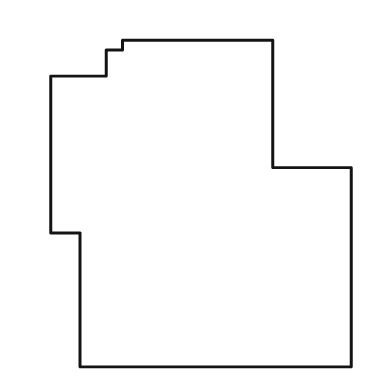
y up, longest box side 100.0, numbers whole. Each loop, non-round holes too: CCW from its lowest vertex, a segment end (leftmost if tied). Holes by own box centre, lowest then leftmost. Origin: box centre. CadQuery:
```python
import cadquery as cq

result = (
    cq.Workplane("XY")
    .moveTo(-37.0, -50.0)
    .lineTo(46.0, -50.0)
    .lineTo(46.0, 11.0)
    .lineTo(22.0, 11.0)
    .lineTo(22.0, 50.0)
    .lineTo(-24.0, 50.0)
    .lineTo(-24.0, 47.0)
    .lineTo(-29.0, 47.0)
    .lineTo(-29.0, 39.0)
    .lineTo(-46.0, 39.0)
    .lineTo(-46.0, -9.0)
    .lineTo(-37.0, -9.0)
    .close()
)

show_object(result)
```